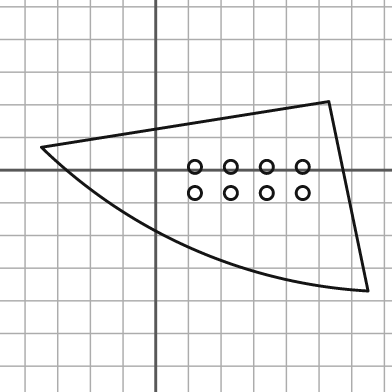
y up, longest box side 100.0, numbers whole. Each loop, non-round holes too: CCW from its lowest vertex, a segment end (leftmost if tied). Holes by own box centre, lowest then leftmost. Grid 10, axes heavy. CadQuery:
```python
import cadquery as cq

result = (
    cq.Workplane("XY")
    .moveTo(65.0, -37.0)
    .lineTo(53.0, 21.0)
    .lineTo(-35.0, 7.0)
    .threePointArc((11.0, -24.0), (65.0, -37.0))
    .close()
    .moveTo(12.0, -7.0)
    .circle(2.0)
    .moveTo(23.0, -7.0)
    .circle(2.0)
    .moveTo(34.0, -7.0)
    .circle(2.0)
    .moveTo(45.0, -7.0)
    .circle(2.0)
    .moveTo(12.0, 1.0)
    .circle(2.0)
    .moveTo(23.0, 1.0)
    .circle(2.0)
    .moveTo(34.0, 1.0)
    .circle(2.0)
    .moveTo(45.0, 1.0)
    .circle(2.0)
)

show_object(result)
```